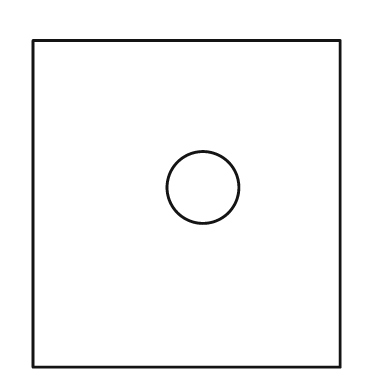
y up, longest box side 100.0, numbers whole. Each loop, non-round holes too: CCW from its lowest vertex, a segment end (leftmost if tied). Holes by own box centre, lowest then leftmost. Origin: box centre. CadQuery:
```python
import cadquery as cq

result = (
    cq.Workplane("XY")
    .moveTo(-47.0, -50.0)
    .lineTo(47.0, -50.0)
    .lineTo(47.0, 50.0)
    .lineTo(-47.0, 50.0)
    .close()
    .moveTo(5.0, 5.0)
    .circle(11.0)
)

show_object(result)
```